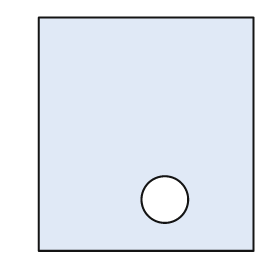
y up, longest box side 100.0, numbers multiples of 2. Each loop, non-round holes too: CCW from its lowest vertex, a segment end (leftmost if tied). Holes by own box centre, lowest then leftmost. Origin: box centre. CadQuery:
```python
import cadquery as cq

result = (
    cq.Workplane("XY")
    .moveTo(-46.0, -50.0)
    .lineTo(46.0, -50.0)
    .lineTo(46.0, 50.0)
    .lineTo(-46.0, 50.0)
    .close()
    .moveTo(8.0, -28.0)
    .circle(10.0)
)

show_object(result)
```